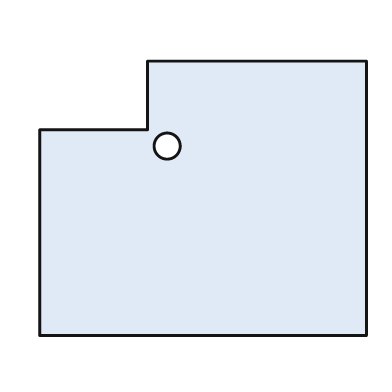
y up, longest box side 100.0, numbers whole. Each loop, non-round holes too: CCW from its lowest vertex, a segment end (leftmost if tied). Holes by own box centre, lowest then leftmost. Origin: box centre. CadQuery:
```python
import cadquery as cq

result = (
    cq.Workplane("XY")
    .moveTo(-50.0, -42.0)
    .lineTo(50.0, -42.0)
    .lineTo(50.0, 42.0)
    .lineTo(-17.0, 42.0)
    .lineTo(-17.0, 21.0)
    .lineTo(-50.0, 21.0)
    .close()
    .moveTo(-11.0, 16.0)
    .circle(4.0)
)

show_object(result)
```